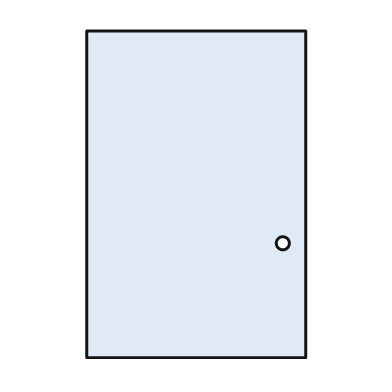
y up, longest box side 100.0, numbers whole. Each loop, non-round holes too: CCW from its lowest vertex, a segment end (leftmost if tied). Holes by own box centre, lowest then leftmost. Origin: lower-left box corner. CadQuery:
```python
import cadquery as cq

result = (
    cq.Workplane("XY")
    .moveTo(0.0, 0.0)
    .lineTo(67.0, 0.0)
    .lineTo(67.0, 100.0)
    .lineTo(0.0, 100.0)
    .close()
    .moveTo(60.0, 35.0)
    .circle(2.0)
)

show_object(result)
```